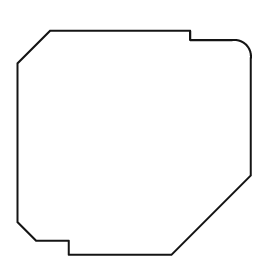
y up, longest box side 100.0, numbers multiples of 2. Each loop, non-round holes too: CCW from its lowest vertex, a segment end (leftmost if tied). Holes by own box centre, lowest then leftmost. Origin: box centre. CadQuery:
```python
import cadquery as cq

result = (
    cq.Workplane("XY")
    .moveTo(-28.0, -48.0)
    .lineTo(16.0, -48.0)
    .lineTo(50.0, -14.0)
    .lineTo(50.0, 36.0)
    .threePointArc((48.0, 42.0), (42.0, 44.0))
    .lineTo(24.0, 44.0)
    .lineTo(24.0, 48.0)
    .lineTo(-36.0, 48.0)
    .lineTo(-50.0, 34.0)
    .lineTo(-50.0, -34.0)
    .lineTo(-42.0, -42.0)
    .lineTo(-28.0, -42.0)
    .close()
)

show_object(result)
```